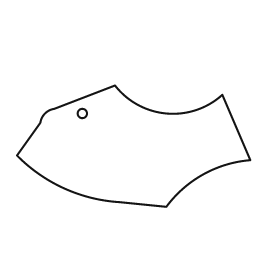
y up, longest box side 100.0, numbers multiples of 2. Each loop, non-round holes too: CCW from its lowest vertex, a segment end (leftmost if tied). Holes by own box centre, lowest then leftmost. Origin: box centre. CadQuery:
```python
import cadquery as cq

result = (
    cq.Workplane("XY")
    .moveTo(14.0, -26.0)
    .threePointArc((30.0, -12.0), (50.0, -6.0))
    .lineTo(38.0, 22.0)
    .threePointArc((14.0, 14.0), (-8.0, 26.0))
    .lineTo(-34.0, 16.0)
    .threePointArc((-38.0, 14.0), (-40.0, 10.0))
    .lineTo(-50.0, -4.0)
    .threePointArc((-30.0, -18.0), (-6.0, -24.0))
    .close()
    .moveTo(-22.0, 14.0)
    .circle(2.0)
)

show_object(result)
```